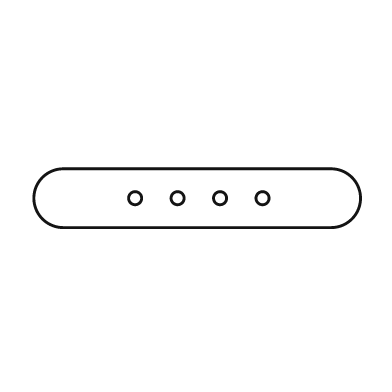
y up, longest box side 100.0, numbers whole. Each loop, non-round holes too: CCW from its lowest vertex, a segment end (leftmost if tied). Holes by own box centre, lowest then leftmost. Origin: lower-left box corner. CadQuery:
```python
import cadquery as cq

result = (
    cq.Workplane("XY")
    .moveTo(9.0, 0.0)
    .lineTo(91.0, 0.0)
    .threePointArc((100.0, 9.0), (91.0, 18.0))
    .lineTo(9.0, 18.0)
    .threePointArc((0.0, 9.0), (9.0, 0.0))
    .close()
    .moveTo(31.0, 9.0)
    .circle(2.0)
    .moveTo(44.0, 9.0)
    .circle(2.0)
    .moveTo(57.0, 9.0)
    .circle(2.0)
    .moveTo(70.0, 9.0)
    .circle(2.0)
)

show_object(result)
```